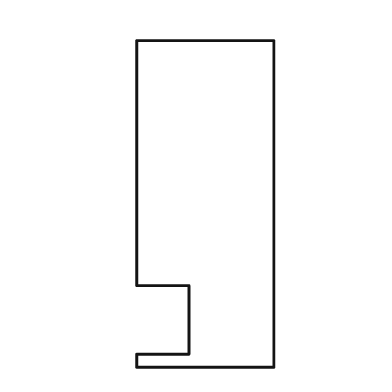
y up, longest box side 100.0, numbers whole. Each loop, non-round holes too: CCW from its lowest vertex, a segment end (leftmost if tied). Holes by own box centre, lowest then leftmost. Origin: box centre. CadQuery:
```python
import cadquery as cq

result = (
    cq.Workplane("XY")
    .moveTo(-21.0, -50.0)
    .lineTo(21.0, -50.0)
    .lineTo(21.0, 50.0)
    .lineTo(-21.0, 50.0)
    .lineTo(-21.0, -25.0)
    .lineTo(-5.0, -25.0)
    .lineTo(-5.0, -46.0)
    .lineTo(-21.0, -46.0)
    .close()
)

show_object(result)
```